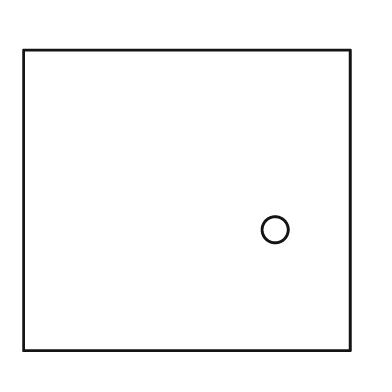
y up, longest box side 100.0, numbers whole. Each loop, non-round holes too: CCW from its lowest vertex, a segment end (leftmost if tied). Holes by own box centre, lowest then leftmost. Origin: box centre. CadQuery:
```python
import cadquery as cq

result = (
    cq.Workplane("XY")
    .moveTo(-50.0, -46.0)
    .lineTo(50.0, -46.0)
    .lineTo(50.0, 46.0)
    .lineTo(-50.0, 46.0)
    .close()
    .moveTo(27.0, -9.0)
    .circle(4.0)
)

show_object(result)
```